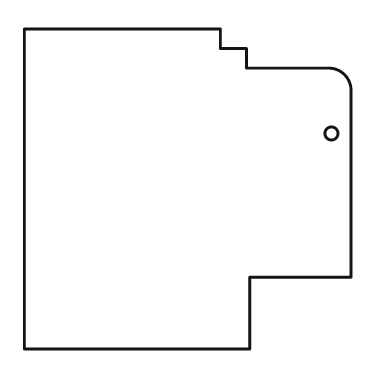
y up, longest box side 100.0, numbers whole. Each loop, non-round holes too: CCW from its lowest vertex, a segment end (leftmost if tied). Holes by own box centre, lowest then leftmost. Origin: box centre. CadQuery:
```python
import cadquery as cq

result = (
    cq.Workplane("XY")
    .moveTo(-50.0, -49.0)
    .lineTo(19.0, -49.0)
    .lineTo(19.0, -27.0)
    .lineTo(50.0, -27.0)
    .lineTo(50.0, 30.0)
    .threePointArc((48.0, 35.0), (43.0, 37.0))
    .lineTo(18.0, 37.0)
    .lineTo(18.0, 43.0)
    .lineTo(10.0, 43.0)
    .lineTo(10.0, 49.0)
    .lineTo(-50.0, 49.0)
    .close()
    .moveTo(44.0, 17.0)
    .circle(2.0)
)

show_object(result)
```